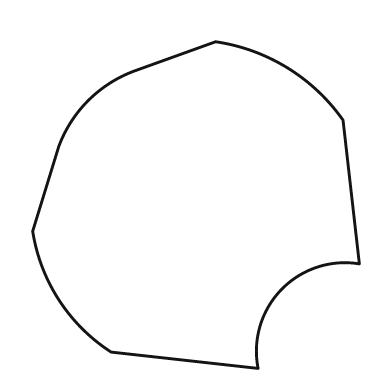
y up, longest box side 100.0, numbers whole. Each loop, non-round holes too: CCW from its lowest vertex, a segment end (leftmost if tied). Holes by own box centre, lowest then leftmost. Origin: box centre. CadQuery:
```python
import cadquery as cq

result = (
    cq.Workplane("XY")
    .moveTo(19.0, -50.0)
    .threePointArc((26.0, -26.0), (50.0, -18.0))
    .lineTo(45.0, 26.0)
    .threePointArc((28.0, 42.0), (6.0, 50.0))
    .lineTo(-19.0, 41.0)
    .threePointArc((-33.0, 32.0), (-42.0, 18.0))
    .lineTo(-50.0, -8.0)
    .threePointArc((-42.0, -29.0), (-26.0, -45.0))
    .close()
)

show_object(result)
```